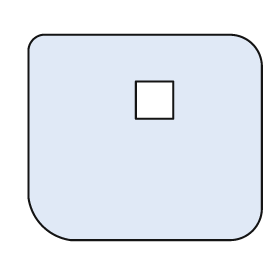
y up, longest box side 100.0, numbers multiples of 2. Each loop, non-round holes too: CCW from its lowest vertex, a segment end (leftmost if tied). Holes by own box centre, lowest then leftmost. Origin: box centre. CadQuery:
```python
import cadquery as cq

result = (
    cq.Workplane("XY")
    .moveTo(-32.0, -44.0)
    .lineTo(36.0, -44.0)
    .threePointArc((46.0, -40.0), (50.0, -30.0))
    .lineTo(50.0, 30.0)
    .threePointArc((46.0, 40.0), (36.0, 44.0))
    .lineTo(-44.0, 44.0)
    .threePointArc((-48.0, 42.0), (-50.0, 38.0))
    .lineTo(-50.0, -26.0)
    .threePointArc((-44.0, -38.0), (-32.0, -44.0))
    .close()
    .moveTo(-4.0, 8.0)
    .lineTo(12.0, 8.0)
    .lineTo(12.0, 24.0)
    .lineTo(-4.0, 24.0)
    .close()
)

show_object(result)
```